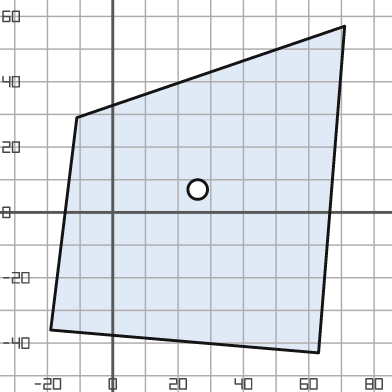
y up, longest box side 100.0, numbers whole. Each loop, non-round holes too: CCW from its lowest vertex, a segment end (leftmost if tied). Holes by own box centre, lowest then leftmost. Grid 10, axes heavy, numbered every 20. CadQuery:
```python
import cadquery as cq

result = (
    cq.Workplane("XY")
    .moveTo(63.0, -43.0)
    .lineTo(71.0, 57.0)
    .lineTo(-11.0, 29.0)
    .lineTo(-19.0, -36.0)
    .close()
    .moveTo(26.0, 7.0)
    .circle(3.0)
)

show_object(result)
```